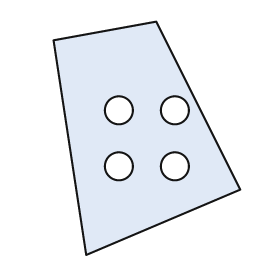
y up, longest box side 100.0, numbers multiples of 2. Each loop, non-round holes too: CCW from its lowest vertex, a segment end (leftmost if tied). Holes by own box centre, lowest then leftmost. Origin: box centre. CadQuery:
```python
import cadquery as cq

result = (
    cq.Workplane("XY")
    .moveTo(-26.0, -50.0)
    .lineTo(40.0, -22.0)
    .lineTo(4.0, 50.0)
    .lineTo(-40.0, 42.0)
    .close()
    .moveTo(-12.0, -12.0)
    .circle(6.0)
    .moveTo(12.0, -12.0)
    .circle(6.0)
    .moveTo(-12.0, 12.0)
    .circle(6.0)
    .moveTo(12.0, 12.0)
    .circle(6.0)
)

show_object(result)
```